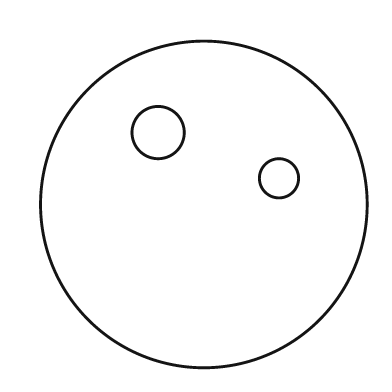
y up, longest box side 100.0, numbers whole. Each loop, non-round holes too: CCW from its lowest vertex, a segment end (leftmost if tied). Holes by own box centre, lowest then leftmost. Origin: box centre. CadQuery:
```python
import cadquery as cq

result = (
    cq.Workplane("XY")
    .moveTo(0.0, 0.0)
    .circle(50.0)
    .moveTo(23.0, 8.0)
    .circle(6.0)
    .moveTo(-14.0, 22.0)
    .circle(8.0)
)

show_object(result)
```